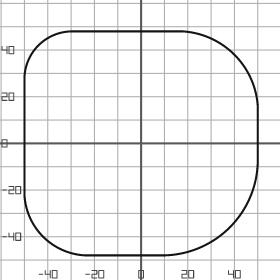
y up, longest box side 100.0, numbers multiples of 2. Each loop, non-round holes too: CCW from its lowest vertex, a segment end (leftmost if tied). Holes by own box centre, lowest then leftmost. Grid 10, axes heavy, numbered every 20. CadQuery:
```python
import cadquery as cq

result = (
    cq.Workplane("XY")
    .moveTo(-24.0, -48.0)
    .lineTo(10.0, -48.0)
    .threePointArc((38.0, -36.0), (50.0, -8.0))
    .lineTo(50.0, 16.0)
    .threePointArc((40.0, 38.0), (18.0, 48.0))
    .lineTo(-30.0, 48.0)
    .threePointArc((-44.0, 42.0), (-50.0, 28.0))
    .lineTo(-50.0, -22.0)
    .threePointArc((-42.0, -40.0), (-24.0, -48.0))
    .close()
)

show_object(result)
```